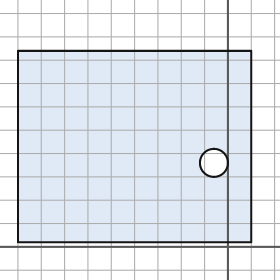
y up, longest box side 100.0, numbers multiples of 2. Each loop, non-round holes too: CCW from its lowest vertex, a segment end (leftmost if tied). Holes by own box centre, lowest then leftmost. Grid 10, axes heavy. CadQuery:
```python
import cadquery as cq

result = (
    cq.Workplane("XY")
    .moveTo(-90.0, 2.0)
    .lineTo(10.0, 2.0)
    .lineTo(10.0, 84.0)
    .lineTo(-90.0, 84.0)
    .close()
    .moveTo(-6.0, 36.0)
    .circle(6.0)
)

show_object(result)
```